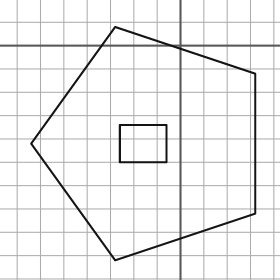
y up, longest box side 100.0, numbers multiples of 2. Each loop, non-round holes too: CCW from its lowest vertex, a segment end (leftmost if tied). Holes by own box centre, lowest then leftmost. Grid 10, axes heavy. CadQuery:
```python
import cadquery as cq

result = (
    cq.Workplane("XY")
    .moveTo(-28.0, -92.0)
    .lineTo(32.0, -72.0)
    .lineTo(32.0, -12.0)
    .lineTo(-28.0, 8.0)
    .lineTo(-64.0, -42.0)
    .close()
    .moveTo(-26.0, -50.0)
    .lineTo(-6.0, -50.0)
    .lineTo(-6.0, -34.0)
    .lineTo(-26.0, -34.0)
    .close()
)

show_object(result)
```